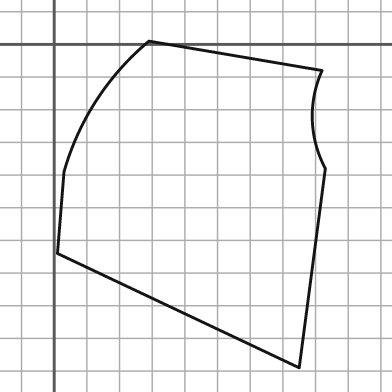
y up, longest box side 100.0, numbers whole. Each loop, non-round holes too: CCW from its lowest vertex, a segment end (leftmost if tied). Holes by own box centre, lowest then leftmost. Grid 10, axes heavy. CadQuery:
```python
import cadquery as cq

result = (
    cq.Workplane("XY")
    .moveTo(75.0, -99.0)
    .lineTo(83.0, -38.0)
    .threePointArc((79.0, -23.0), (82.0, -8.0))
    .lineTo(29.0, 1.0)
    .threePointArc((13.0, -17.0), (3.0, -39.0))
    .lineTo(1.0, -64.0)
    .close()
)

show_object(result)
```